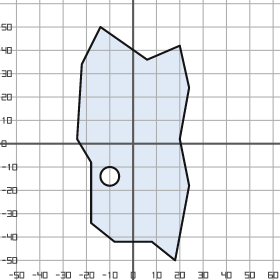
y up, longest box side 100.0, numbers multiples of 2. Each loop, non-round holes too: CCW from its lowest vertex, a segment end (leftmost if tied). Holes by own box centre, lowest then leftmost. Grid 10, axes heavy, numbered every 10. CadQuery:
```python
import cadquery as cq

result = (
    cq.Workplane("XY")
    .moveTo(18.0, -50.0)
    .lineTo(24.0, -18.0)
    .lineTo(20.0, 2.0)
    .lineTo(24.0, 24.0)
    .lineTo(20.0, 42.0)
    .lineTo(6.0, 36.0)
    .lineTo(-14.0, 50.0)
    .lineTo(-22.0, 34.0)
    .lineTo(-24.0, 2.0)
    .lineTo(-18.0, -8.0)
    .lineTo(-18.0, -34.0)
    .lineTo(-8.0, -42.0)
    .lineTo(8.0, -42.0)
    .close()
    .moveTo(-10.0, -14.0)
    .circle(4.0)
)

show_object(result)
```